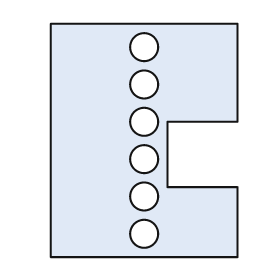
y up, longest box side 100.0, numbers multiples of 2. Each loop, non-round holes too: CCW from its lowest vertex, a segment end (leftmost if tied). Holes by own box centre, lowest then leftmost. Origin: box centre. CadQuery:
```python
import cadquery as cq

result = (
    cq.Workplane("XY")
    .moveTo(-40.0, -50.0)
    .lineTo(40.0, -50.0)
    .lineTo(40.0, -20.0)
    .lineTo(10.0, -20.0)
    .lineTo(10.0, 8.0)
    .lineTo(40.0, 8.0)
    .lineTo(40.0, 50.0)
    .lineTo(-40.0, 50.0)
    .close()
    .moveTo(0.0, -40.0)
    .circle(6.0)
    .moveTo(0.0, -24.0)
    .circle(6.0)
    .moveTo(0.0, -8.0)
    .circle(6.0)
    .moveTo(0.0, 8.0)
    .circle(6.0)
    .moveTo(0.0, 24.0)
    .circle(6.0)
    .moveTo(0.0, 40.0)
    .circle(6.0)
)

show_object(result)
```